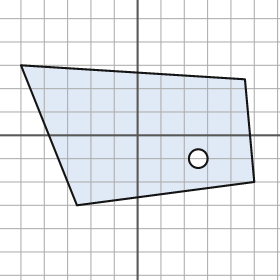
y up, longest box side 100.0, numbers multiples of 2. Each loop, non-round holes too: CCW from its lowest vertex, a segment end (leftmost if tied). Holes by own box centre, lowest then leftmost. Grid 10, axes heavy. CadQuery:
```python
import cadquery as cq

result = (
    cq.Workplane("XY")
    .moveTo(-26.0, -30.0)
    .lineTo(50.0, -20.0)
    .lineTo(46.0, 24.0)
    .lineTo(-50.0, 30.0)
    .close()
    .moveTo(26.0, -10.0)
    .circle(4.0)
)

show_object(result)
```